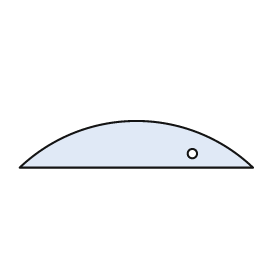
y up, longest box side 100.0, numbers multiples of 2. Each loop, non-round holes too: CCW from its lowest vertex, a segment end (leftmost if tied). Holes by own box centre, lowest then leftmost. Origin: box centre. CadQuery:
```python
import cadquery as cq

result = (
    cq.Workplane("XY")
    .moveTo(-50.0, -10.0)
    .lineTo(50.0, -10.0)
    .threePointArc((0.0, 10.0), (-50.0, -10.0))
    .close()
    .moveTo(24.0, -4.0)
    .circle(2.0)
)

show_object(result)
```